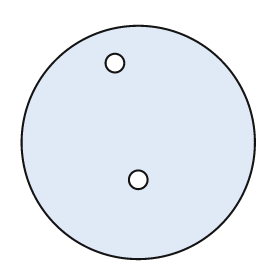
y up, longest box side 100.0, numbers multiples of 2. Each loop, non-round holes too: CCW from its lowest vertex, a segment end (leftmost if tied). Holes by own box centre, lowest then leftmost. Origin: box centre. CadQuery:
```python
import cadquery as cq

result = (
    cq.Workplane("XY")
    .moveTo(0.0, 0.0)
    .circle(50.0)
    .moveTo(0.0, -16.0)
    .circle(4.0)
    .moveTo(-10.0, 34.0)
    .circle(4.0)
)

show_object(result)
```